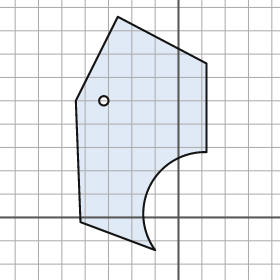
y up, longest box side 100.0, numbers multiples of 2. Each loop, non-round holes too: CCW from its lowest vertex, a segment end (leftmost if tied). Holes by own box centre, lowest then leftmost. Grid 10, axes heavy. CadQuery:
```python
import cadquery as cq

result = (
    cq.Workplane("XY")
    .moveTo(-10.0, -14.0)
    .threePointArc((-12.0, 14.0), (12.0, 28.0))
    .lineTo(12.0, 66.0)
    .lineTo(-26.0, 86.0)
    .lineTo(-44.0, 50.0)
    .lineTo(-42.0, -2.0)
    .close()
    .moveTo(-32.0, 50.0)
    .circle(2.0)
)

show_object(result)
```